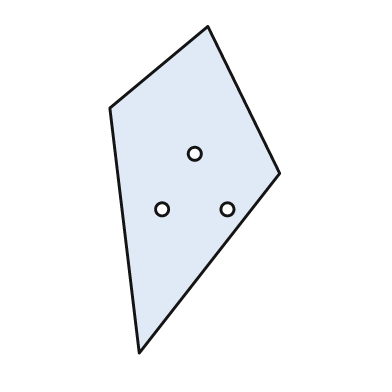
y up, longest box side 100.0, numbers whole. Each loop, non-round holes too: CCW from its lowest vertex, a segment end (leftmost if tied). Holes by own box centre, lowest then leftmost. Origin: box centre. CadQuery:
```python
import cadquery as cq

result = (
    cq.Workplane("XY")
    .moveTo(-17.0, -50.0)
    .lineTo(26.0, 5.0)
    .lineTo(4.0, 50.0)
    .lineTo(-26.0, 25.0)
    .close()
    .moveTo(-10.0, -6.0)
    .circle(2.0)
    .moveTo(10.0, -6.0)
    .circle(2.0)
    .moveTo(0.0, 11.0)
    .circle(2.0)
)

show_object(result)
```